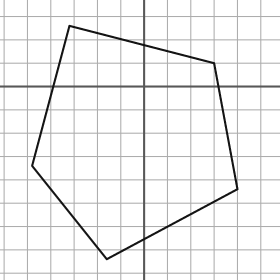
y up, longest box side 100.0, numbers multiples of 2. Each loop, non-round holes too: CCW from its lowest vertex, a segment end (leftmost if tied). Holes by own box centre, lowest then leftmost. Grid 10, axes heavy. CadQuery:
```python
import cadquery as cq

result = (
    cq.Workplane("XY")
    .moveTo(-16.0, -74.0)
    .lineTo(40.0, -44.0)
    .lineTo(30.0, 10.0)
    .lineTo(-32.0, 26.0)
    .lineTo(-48.0, -34.0)
    .close()
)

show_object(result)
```